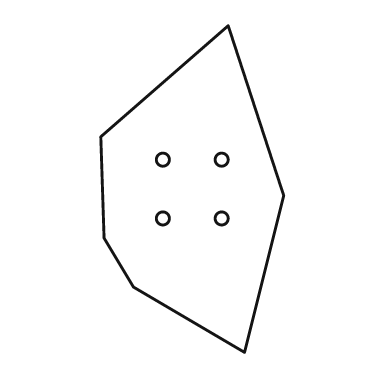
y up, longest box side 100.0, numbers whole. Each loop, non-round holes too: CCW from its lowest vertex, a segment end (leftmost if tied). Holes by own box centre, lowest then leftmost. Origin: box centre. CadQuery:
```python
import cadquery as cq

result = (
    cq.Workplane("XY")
    .moveTo(16.0, -50.0)
    .lineTo(28.0, -2.0)
    .lineTo(11.0, 50.0)
    .lineTo(-28.0, 16.0)
    .lineTo(-27.0, -15.0)
    .lineTo(-18.0, -30.0)
    .close()
    .moveTo(-9.0, -9.0)
    .circle(2.0)
    .moveTo(9.0, -9.0)
    .circle(2.0)
    .moveTo(-9.0, 9.0)
    .circle(2.0)
    .moveTo(9.0, 9.0)
    .circle(2.0)
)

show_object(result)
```